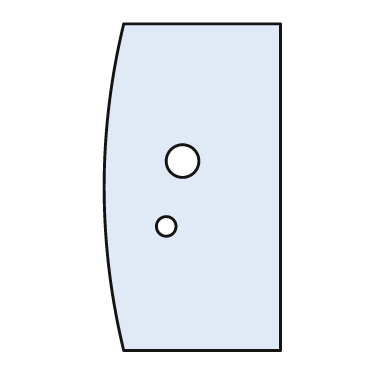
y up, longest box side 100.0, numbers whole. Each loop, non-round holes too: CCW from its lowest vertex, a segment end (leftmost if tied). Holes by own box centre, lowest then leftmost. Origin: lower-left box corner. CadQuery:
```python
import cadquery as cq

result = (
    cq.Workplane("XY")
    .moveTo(6.0, 0.0)
    .lineTo(54.0, 0.0)
    .lineTo(54.0, 100.0)
    .lineTo(6.0, 100.0)
    .threePointArc((0.0, 50.0), (6.0, 0.0))
    .close()
    .moveTo(19.0, 38.0)
    .circle(3.0)
    .moveTo(24.0, 58.0)
    .circle(5.0)
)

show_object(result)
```